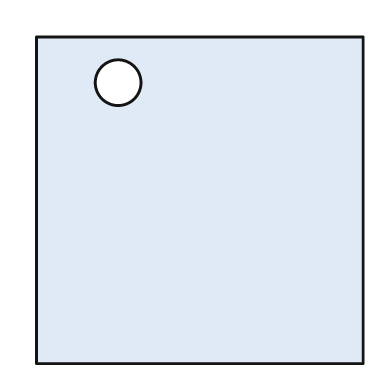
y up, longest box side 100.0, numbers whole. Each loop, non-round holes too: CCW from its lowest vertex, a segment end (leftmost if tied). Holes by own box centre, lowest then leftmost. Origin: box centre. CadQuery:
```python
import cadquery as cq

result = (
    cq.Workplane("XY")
    .moveTo(-50.0, -50.0)
    .lineTo(50.0, -50.0)
    .lineTo(50.0, 50.0)
    .lineTo(-50.0, 50.0)
    .close()
    .moveTo(-25.0, 36.0)
    .circle(7.0)
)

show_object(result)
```